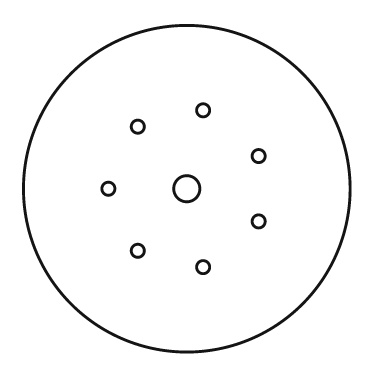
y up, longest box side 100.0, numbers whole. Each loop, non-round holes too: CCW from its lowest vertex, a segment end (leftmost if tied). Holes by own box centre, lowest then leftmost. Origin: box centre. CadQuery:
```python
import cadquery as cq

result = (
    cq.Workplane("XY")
    .moveTo(0.0, 0.0)
    .circle(50.0)
    .moveTo(5.0, -24.0)
    .circle(2.0)
    .moveTo(-15.0, -19.0)
    .circle(2.0)
    .moveTo(22.0, -10.0)
    .circle(2.0)
    .moveTo(-24.0, 0.0)
    .circle(2.0)
    .moveTo(0.0, 0.0)
    .circle(4.0)
    .moveTo(22.0, 10.0)
    .circle(2.0)
    .moveTo(-15.0, 19.0)
    .circle(2.0)
    .moveTo(5.0, 24.0)
    .circle(2.0)
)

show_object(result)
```